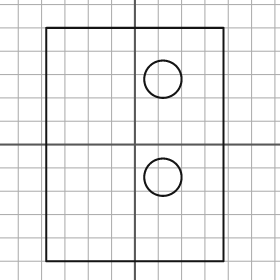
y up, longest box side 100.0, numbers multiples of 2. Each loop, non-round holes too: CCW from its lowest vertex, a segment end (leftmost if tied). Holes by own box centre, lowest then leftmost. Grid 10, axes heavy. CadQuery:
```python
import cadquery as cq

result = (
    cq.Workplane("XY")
    .moveTo(-38.0, -50.0)
    .lineTo(38.0, -50.0)
    .lineTo(38.0, 50.0)
    .lineTo(-38.0, 50.0)
    .close()
    .moveTo(12.0, -14.0)
    .circle(8.0)
    .moveTo(12.0, 28.0)
    .circle(8.0)
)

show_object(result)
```